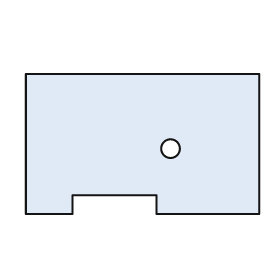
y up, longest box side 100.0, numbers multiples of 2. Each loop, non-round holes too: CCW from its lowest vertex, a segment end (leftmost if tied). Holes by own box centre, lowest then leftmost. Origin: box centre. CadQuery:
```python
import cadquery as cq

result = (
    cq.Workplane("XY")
    .moveTo(-50.0, -30.0)
    .lineTo(-30.0, -30.0)
    .lineTo(-30.0, -22.0)
    .lineTo(6.0, -22.0)
    .lineTo(6.0, -30.0)
    .lineTo(50.0, -30.0)
    .lineTo(50.0, 30.0)
    .lineTo(-50.0, 30.0)
    .close()
    .moveTo(12.0, -2.0)
    .circle(4.0)
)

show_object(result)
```